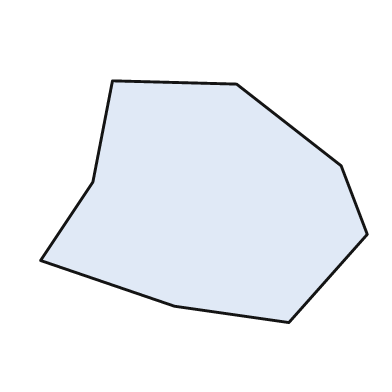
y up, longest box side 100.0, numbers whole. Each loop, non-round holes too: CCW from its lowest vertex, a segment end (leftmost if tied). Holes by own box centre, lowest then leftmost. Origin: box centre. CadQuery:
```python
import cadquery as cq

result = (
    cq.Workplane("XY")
    .moveTo(26.0, -37.0)
    .lineTo(50.0, -10.0)
    .lineTo(42.0, 11.0)
    .lineTo(10.0, 36.0)
    .lineTo(-28.0, 37.0)
    .lineTo(-34.0, 6.0)
    .lineTo(-50.0, -18.0)
    .lineTo(-9.0, -32.0)
    .close()
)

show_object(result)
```